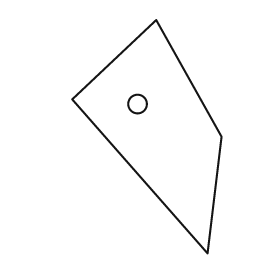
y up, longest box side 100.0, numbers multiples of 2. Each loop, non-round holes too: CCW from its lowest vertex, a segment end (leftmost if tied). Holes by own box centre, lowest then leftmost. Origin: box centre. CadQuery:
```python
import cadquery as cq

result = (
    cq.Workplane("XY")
    .moveTo(26.0, -50.0)
    .lineTo(32.0, 0.0)
    .lineTo(4.0, 50.0)
    .lineTo(-32.0, 16.0)
    .close()
    .moveTo(-4.0, 14.0)
    .circle(4.0)
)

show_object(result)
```